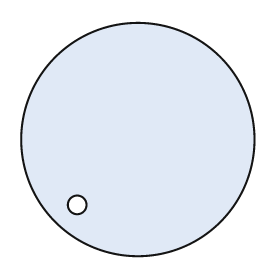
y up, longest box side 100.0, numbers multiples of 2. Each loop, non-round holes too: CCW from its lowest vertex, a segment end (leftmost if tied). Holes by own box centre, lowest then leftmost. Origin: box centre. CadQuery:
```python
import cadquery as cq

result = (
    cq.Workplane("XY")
    .moveTo(0.0, 0.0)
    .circle(50.0)
    .moveTo(-26.0, -28.0)
    .circle(4.0)
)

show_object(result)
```